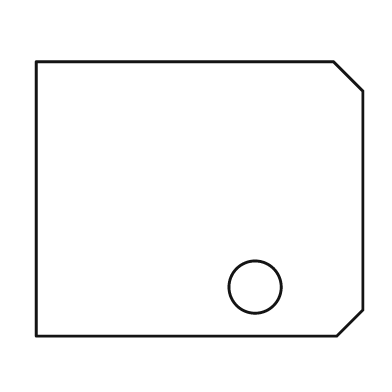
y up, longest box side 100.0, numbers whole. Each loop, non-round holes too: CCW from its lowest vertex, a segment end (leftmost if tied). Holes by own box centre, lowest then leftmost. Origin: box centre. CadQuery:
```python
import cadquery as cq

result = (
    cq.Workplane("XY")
    .moveTo(-50.0, -42.0)
    .lineTo(42.0, -42.0)
    .lineTo(50.0, -34.0)
    .lineTo(50.0, 33.0)
    .lineTo(41.0, 42.0)
    .lineTo(-50.0, 42.0)
    .close()
    .moveTo(17.0, -27.0)
    .circle(8.0)
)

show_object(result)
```